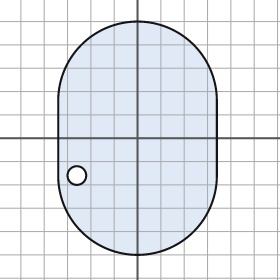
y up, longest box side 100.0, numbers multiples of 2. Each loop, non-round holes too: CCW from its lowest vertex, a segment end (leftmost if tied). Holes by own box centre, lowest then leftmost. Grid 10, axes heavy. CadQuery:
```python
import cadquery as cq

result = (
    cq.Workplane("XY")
    .moveTo(-34.0, -16.0)
    .threePointArc((0.0, -50.0), (34.0, -16.0))
    .lineTo(34.0, 16.0)
    .threePointArc((0.0, 50.0), (-34.0, 16.0))
    .close()
    .moveTo(-26.0, -16.0)
    .circle(4.0)
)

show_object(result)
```